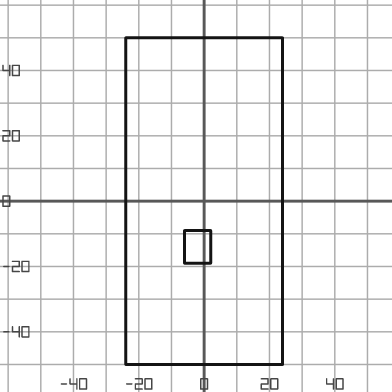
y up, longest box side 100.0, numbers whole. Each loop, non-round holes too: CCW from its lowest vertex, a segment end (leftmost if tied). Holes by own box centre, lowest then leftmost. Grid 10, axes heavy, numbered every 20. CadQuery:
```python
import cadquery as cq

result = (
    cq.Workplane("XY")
    .moveTo(-24.0, -50.0)
    .lineTo(24.0, -50.0)
    .lineTo(24.0, 50.0)
    .lineTo(-24.0, 50.0)
    .close()
    .moveTo(-6.0, -19.0)
    .lineTo(2.0, -19.0)
    .lineTo(2.0, -9.0)
    .lineTo(-6.0, -9.0)
    .close()
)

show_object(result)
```